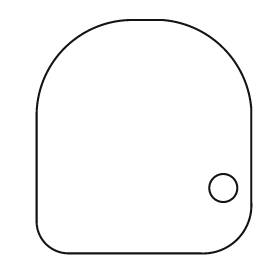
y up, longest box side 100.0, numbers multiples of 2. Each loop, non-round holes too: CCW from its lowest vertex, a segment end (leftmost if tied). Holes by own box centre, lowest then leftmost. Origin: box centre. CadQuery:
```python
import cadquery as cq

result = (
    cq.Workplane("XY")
    .moveTo(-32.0, -50.0)
    .lineTo(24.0, -50.0)
    .threePointArc((40.0, -44.0), (46.0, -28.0))
    .lineTo(46.0, 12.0)
    .threePointArc((34.0, 38.0), (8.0, 50.0))
    .lineTo(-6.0, 50.0)
    .threePointArc((-34.0, 38.0), (-46.0, 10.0))
    .lineTo(-46.0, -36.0)
    .threePointArc((-42.0, -46.0), (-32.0, -50.0))
    .close()
    .moveTo(34.0, -22.0)
    .circle(6.0)
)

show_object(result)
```